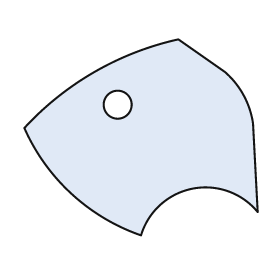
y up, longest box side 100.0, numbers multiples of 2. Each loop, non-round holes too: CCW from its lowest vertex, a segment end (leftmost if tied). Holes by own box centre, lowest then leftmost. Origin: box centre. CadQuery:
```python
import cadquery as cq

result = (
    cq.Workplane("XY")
    .moveTo(0.0, -42.0)
    .threePointArc((22.0, -22.0), (50.0, -32.0))
    .lineTo(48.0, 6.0)
    .threePointArc((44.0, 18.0), (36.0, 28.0))
    .lineTo(16.0, 42.0)
    .threePointArc((-20.0, 28.0), (-50.0, 4.0))
    .threePointArc((-30.0, -24.0), (0.0, -42.0))
    .close()
    .moveTo(-10.0, 14.0)
    .circle(6.0)
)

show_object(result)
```